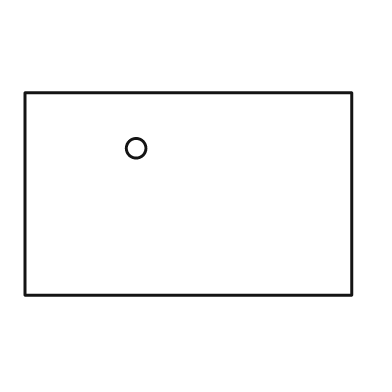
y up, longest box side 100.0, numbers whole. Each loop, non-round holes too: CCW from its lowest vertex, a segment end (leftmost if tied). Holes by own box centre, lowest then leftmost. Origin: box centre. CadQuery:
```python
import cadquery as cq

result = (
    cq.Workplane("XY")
    .moveTo(-50.0, -31.0)
    .lineTo(50.0, -31.0)
    .lineTo(50.0, 31.0)
    .lineTo(-50.0, 31.0)
    .close()
    .moveTo(-16.0, 14.0)
    .circle(3.0)
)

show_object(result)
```